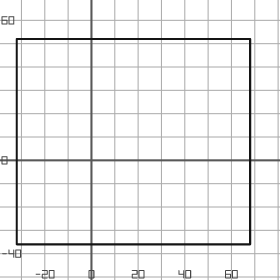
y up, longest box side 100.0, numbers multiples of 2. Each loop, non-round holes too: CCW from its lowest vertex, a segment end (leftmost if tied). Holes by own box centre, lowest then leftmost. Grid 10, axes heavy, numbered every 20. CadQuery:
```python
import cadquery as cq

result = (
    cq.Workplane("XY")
    .moveTo(-32.0, -36.0)
    .lineTo(68.0, -36.0)
    .lineTo(68.0, 52.0)
    .lineTo(-32.0, 52.0)
    .close()
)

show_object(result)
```